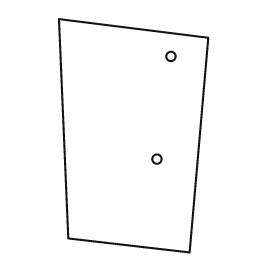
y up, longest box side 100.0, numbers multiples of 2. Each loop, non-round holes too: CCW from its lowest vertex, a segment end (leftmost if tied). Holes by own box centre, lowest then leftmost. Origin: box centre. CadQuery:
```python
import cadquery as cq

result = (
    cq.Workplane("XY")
    .moveTo(24.0, -50.0)
    .lineTo(32.0, 42.0)
    .lineTo(-32.0, 50.0)
    .lineTo(-28.0, -44.0)
    .close()
    .moveTo(10.0, -10.0)
    .circle(2.0)
    .moveTo(16.0, 34.0)
    .circle(2.0)
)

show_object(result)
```